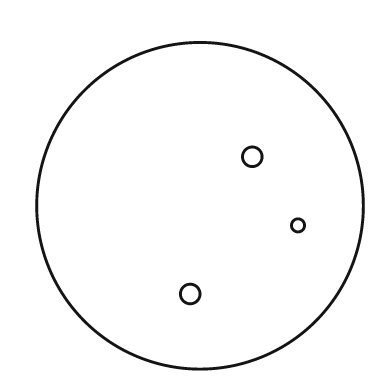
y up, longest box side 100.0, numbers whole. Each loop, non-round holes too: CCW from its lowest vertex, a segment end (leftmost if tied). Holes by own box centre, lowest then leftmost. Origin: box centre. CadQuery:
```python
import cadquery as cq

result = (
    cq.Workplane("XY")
    .moveTo(0.0, 0.0)
    .circle(50.0)
    .moveTo(-3.0, -27.0)
    .circle(3.0)
    .moveTo(30.0, -6.0)
    .circle(2.0)
    .moveTo(16.0, 15.0)
    .circle(3.0)
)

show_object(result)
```